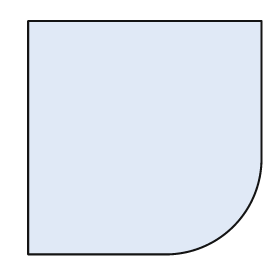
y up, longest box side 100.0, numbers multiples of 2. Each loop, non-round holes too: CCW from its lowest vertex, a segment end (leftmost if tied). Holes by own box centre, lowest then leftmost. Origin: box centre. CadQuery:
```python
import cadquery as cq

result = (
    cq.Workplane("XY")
    .moveTo(-50.0, -50.0)
    .lineTo(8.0, -50.0)
    .threePointArc((38.0, -38.0), (50.0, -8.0))
    .lineTo(50.0, 50.0)
    .lineTo(-50.0, 50.0)
    .close()
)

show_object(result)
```